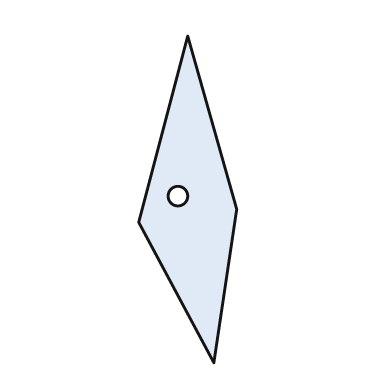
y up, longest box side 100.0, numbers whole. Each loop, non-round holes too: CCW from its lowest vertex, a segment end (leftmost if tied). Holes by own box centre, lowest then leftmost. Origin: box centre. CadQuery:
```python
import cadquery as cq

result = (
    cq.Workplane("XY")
    .moveTo(8.0, -50.0)
    .lineTo(15.0, -3.0)
    .lineTo(0.0, 50.0)
    .lineTo(-15.0, -7.0)
    .close()
    .moveTo(-3.0, 1.0)
    .circle(3.0)
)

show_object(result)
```